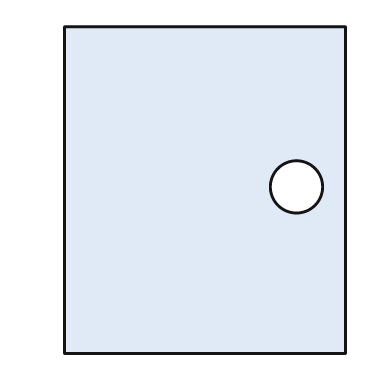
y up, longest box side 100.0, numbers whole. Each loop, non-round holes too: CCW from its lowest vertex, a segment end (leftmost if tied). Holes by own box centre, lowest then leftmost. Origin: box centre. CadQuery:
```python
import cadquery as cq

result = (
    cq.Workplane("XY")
    .moveTo(-43.0, -50.0)
    .lineTo(43.0, -50.0)
    .lineTo(43.0, 50.0)
    .lineTo(-43.0, 50.0)
    .close()
    .moveTo(28.0, 1.0)
    .circle(8.0)
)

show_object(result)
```